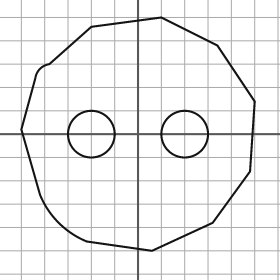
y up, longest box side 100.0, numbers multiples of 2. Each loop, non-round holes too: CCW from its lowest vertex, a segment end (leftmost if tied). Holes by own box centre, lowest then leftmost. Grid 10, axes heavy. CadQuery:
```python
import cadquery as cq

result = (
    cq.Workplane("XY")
    .moveTo(6.0, -50.0)
    .lineTo(32.0, -38.0)
    .lineTo(48.0, -16.0)
    .lineTo(50.0, 14.0)
    .lineTo(34.0, 38.0)
    .lineTo(10.0, 50.0)
    .lineTo(-20.0, 46.0)
    .lineTo(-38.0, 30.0)
    .threePointArc((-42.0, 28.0), (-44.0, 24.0))
    .lineTo(-50.0, 2.0)
    .lineTo(-42.0, -26.0)
    .threePointArc((-34.0, -38.0), (-22.0, -46.0))
    .close()
    .moveTo(-20.0, 0.0)
    .circle(10.0)
    .moveTo(20.0, 0.0)
    .circle(10.0)
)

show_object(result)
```